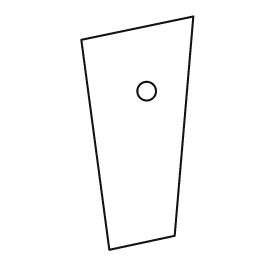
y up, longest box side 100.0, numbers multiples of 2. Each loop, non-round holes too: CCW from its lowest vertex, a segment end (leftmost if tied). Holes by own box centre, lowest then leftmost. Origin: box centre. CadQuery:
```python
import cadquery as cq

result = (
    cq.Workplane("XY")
    .moveTo(-12.0, -50.0)
    .lineTo(16.0, -44.0)
    .lineTo(24.0, 50.0)
    .lineTo(-24.0, 40.0)
    .close()
    .moveTo(4.0, 18.0)
    .circle(4.0)
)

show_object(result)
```